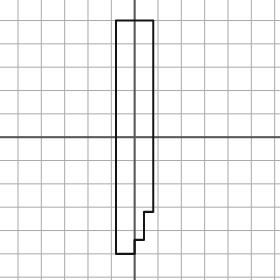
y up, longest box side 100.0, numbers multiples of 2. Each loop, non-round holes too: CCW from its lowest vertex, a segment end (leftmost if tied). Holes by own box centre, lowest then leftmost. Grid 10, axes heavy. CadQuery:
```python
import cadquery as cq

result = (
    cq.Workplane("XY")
    .moveTo(-8.0, -50.0)
    .lineTo(0.0, -50.0)
    .lineTo(0.0, -44.0)
    .lineTo(4.0, -44.0)
    .lineTo(4.0, -32.0)
    .lineTo(8.0, -32.0)
    .lineTo(8.0, 50.0)
    .lineTo(-8.0, 50.0)
    .close()
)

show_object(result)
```